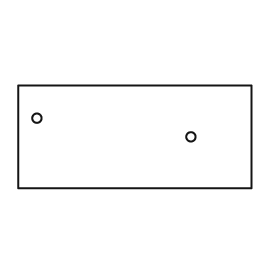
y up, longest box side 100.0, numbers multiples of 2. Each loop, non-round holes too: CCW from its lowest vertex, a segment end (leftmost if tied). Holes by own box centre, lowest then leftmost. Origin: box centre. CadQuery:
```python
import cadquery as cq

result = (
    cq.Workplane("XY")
    .moveTo(-50.0, -22.0)
    .lineTo(50.0, -22.0)
    .lineTo(50.0, 22.0)
    .lineTo(-50.0, 22.0)
    .close()
    .moveTo(24.0, 0.0)
    .circle(2.0)
    .moveTo(-42.0, 8.0)
    .circle(2.0)
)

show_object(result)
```